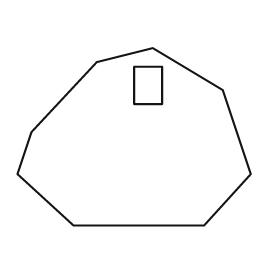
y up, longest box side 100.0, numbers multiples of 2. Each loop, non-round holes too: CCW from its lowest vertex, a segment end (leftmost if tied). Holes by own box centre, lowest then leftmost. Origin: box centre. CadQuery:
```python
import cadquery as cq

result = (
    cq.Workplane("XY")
    .moveTo(-26.0, -38.0)
    .lineTo(30.0, -38.0)
    .lineTo(50.0, -16.0)
    .lineTo(38.0, 20.0)
    .lineTo(8.0, 38.0)
    .lineTo(-16.0, 32.0)
    .lineTo(-44.0, 2.0)
    .lineTo(-50.0, -16.0)
    .close()
    .moveTo(0.0, 14.0)
    .lineTo(12.0, 14.0)
    .lineTo(12.0, 30.0)
    .lineTo(0.0, 30.0)
    .close()
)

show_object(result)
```